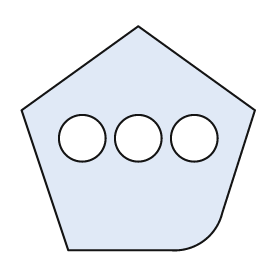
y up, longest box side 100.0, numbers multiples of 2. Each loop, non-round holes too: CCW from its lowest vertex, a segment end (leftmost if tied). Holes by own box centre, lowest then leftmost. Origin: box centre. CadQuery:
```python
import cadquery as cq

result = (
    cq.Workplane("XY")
    .moveTo(-30.0, -48.0)
    .lineTo(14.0, -48.0)
    .threePointArc((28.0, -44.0), (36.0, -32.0))
    .lineTo(50.0, 12.0)
    .lineTo(0.0, 48.0)
    .lineTo(-50.0, 12.0)
    .close()
    .moveTo(-24.0, 0.0)
    .circle(10.0)
    .moveTo(0.0, 0.0)
    .circle(10.0)
    .moveTo(24.0, 0.0)
    .circle(10.0)
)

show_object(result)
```